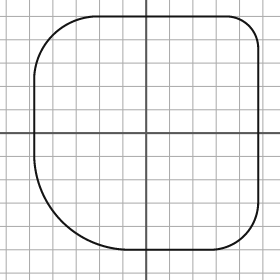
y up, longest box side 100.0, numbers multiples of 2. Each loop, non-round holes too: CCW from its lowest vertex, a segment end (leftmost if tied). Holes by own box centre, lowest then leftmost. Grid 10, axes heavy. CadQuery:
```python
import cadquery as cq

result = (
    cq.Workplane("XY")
    .moveTo(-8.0, -50.0)
    .lineTo(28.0, -50.0)
    .threePointArc((42.0, -44.0), (48.0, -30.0))
    .lineTo(48.0, 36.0)
    .threePointArc((44.0, 46.0), (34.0, 50.0))
    .lineTo(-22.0, 50.0)
    .threePointArc((-40.0, 42.0), (-48.0, 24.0))
    .lineTo(-48.0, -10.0)
    .threePointArc((-36.0, -38.0), (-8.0, -50.0))
    .close()
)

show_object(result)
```